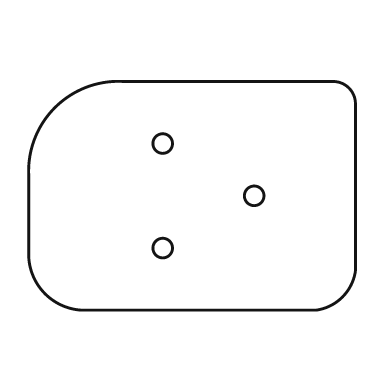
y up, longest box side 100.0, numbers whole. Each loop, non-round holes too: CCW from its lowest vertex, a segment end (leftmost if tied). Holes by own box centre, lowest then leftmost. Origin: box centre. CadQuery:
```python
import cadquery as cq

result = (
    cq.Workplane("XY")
    .moveTo(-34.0, -35.0)
    .lineTo(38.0, -35.0)
    .threePointArc((46.0, -31.0), (50.0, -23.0))
    .lineTo(50.0, 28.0)
    .threePointArc((48.0, 33.0), (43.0, 35.0))
    .lineTo(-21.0, 35.0)
    .threePointArc((-42.0, 27.0), (-50.0, 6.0))
    .lineTo(-50.0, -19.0)
    .threePointArc((-45.0, -30.0), (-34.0, -35.0))
    .close()
    .moveTo(-9.0, -16.0)
    .circle(3.0)
    .moveTo(19.0, 0.0)
    .circle(3.0)
    .moveTo(-9.0, 16.0)
    .circle(3.0)
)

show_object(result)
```